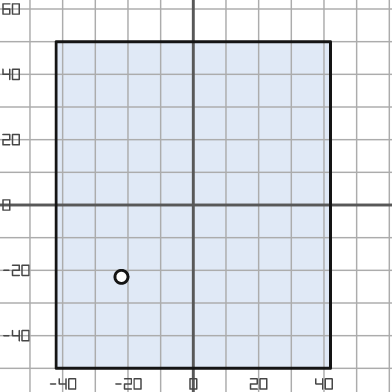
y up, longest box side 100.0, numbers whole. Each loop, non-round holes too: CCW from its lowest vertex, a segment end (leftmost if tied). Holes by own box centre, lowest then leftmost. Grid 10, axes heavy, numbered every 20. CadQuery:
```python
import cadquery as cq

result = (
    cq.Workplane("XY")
    .moveTo(-42.0, -50.0)
    .lineTo(42.0, -50.0)
    .lineTo(42.0, 50.0)
    .lineTo(-42.0, 50.0)
    .close()
    .moveTo(-22.0, -22.0)
    .circle(2.0)
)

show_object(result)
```